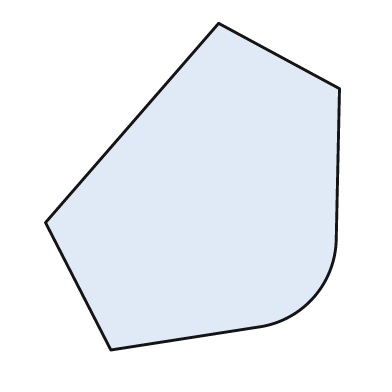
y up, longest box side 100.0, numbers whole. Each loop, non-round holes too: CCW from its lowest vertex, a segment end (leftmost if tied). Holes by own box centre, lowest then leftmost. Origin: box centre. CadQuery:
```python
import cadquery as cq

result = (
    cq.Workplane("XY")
    .moveTo(-25.0, -50.0)
    .lineTo(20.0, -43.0)
    .threePointArc((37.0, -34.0), (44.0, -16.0))
    .lineTo(45.0, 30.0)
    .lineTo(8.0, 50.0)
    .lineTo(-45.0, -11.0)
    .close()
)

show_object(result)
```